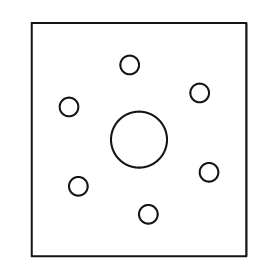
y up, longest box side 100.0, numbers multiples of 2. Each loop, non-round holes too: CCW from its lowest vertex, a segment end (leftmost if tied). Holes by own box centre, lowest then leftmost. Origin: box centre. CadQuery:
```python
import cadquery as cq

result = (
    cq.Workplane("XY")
    .moveTo(-46.0, -50.0)
    .lineTo(46.0, -50.0)
    .lineTo(46.0, 50.0)
    .lineTo(-46.0, 50.0)
    .close()
    .moveTo(4.0, -32.0)
    .circle(4.0)
    .moveTo(-26.0, -20.0)
    .circle(4.0)
    .moveTo(30.0, -14.0)
    .circle(4.0)
    .moveTo(0.0, 0.0)
    .circle(12.0)
    .moveTo(-30.0, 14.0)
    .circle(4.0)
    .moveTo(26.0, 20.0)
    .circle(4.0)
    .moveTo(-4.0, 32.0)
    .circle(4.0)
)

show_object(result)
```